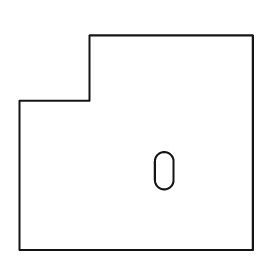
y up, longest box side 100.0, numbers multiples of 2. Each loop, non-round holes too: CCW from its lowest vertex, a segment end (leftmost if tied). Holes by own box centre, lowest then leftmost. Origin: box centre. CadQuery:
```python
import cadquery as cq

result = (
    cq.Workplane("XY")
    .moveTo(-50.0, -46.0)
    .lineTo(50.0, -46.0)
    .lineTo(50.0, 46.0)
    .lineTo(-20.0, 46.0)
    .lineTo(-20.0, 18.0)
    .lineTo(-50.0, 18.0)
    .close()
    .moveTo(8.0, -16.0)
    .threePointArc((12.0, -20.0), (16.0, -16.0))
    .lineTo(16.0, -8.0)
    .threePointArc((12.0, -4.0), (8.0, -8.0))
    .close()
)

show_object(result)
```